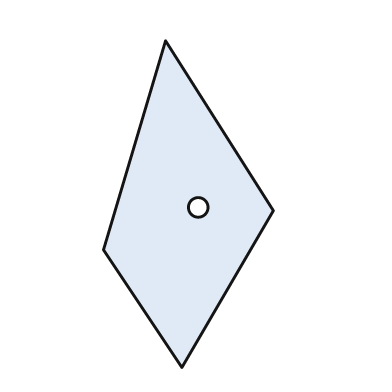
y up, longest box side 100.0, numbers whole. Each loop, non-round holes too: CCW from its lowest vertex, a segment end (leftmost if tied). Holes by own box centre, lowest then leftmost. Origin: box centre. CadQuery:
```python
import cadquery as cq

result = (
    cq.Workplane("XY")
    .moveTo(-2.0, -50.0)
    .lineTo(26.0, -2.0)
    .lineTo(-7.0, 50.0)
    .lineTo(-26.0, -14.0)
    .close()
    .moveTo(3.0, -1.0)
    .circle(3.0)
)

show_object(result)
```